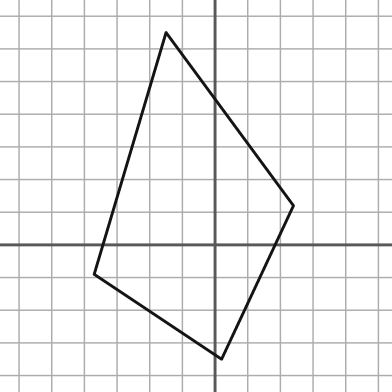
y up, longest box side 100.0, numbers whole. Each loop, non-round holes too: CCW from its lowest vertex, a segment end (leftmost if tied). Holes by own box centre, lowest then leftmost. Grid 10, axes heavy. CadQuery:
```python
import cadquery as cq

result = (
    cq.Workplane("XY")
    .moveTo(2.0, -35.0)
    .lineTo(24.0, 12.0)
    .lineTo(-15.0, 65.0)
    .lineTo(-37.0, -9.0)
    .close()
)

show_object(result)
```